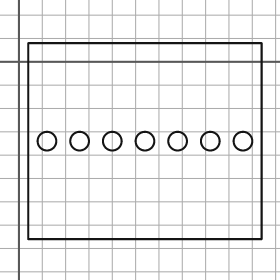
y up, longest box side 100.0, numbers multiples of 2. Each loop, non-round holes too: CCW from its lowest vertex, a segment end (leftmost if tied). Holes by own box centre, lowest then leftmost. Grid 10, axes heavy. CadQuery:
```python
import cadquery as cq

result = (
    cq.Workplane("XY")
    .moveTo(4.0, -76.0)
    .lineTo(104.0, -76.0)
    .lineTo(104.0, 8.0)
    .lineTo(4.0, 8.0)
    .close()
    .moveTo(12.0, -34.0)
    .circle(4.0)
    .moveTo(26.0, -34.0)
    .circle(4.0)
    .moveTo(40.0, -34.0)
    .circle(4.0)
    .moveTo(54.0, -34.0)
    .circle(4.0)
    .moveTo(68.0, -34.0)
    .circle(4.0)
    .moveTo(82.0, -34.0)
    .circle(4.0)
    .moveTo(96.0, -34.0)
    .circle(4.0)
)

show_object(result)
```